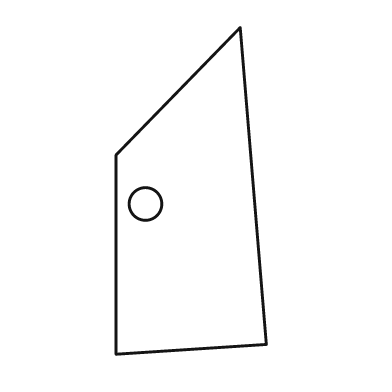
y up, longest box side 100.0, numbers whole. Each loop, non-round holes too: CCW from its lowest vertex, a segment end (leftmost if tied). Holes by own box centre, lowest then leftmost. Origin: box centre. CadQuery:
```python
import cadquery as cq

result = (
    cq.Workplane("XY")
    .moveTo(-23.0, -50.0)
    .lineTo(23.0, -47.0)
    .lineTo(15.0, 50.0)
    .lineTo(-23.0, 11.0)
    .close()
    .moveTo(-14.0, -4.0)
    .circle(5.0)
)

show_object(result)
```